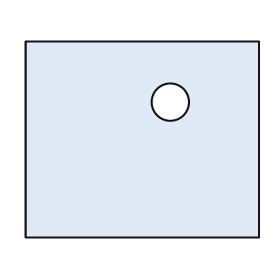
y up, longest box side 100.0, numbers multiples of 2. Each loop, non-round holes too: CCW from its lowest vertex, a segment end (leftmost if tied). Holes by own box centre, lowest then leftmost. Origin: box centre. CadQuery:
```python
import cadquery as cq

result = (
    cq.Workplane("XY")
    .moveTo(-50.0, -42.0)
    .lineTo(50.0, -42.0)
    .lineTo(50.0, 42.0)
    .lineTo(-50.0, 42.0)
    .close()
    .moveTo(12.0, 16.0)
    .circle(8.0)
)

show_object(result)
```